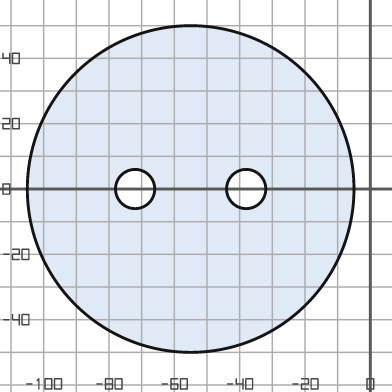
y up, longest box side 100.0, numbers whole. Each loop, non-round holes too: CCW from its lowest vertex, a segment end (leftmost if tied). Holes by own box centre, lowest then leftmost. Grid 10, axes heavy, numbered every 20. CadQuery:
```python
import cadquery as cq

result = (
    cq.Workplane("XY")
    .moveTo(-55.0, 0.0)
    .circle(50.0)
    .moveTo(-72.0, 0.0)
    .circle(6.0)
    .moveTo(-38.0, 0.0)
    .circle(6.0)
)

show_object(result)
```